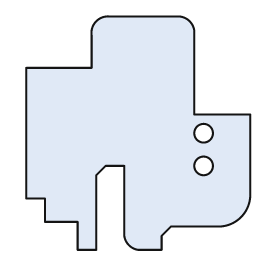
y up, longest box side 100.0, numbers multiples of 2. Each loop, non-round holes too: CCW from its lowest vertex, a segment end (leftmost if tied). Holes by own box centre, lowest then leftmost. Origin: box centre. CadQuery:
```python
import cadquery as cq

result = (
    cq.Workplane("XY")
    .moveTo(-26.0, -50.0)
    .lineTo(-18.0, -50.0)
    .lineTo(-18.0, -18.0)
    .lineTo(-14.0, -14.0)
    .lineTo(-6.0, -14.0)
    .lineTo(-6.0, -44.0)
    .threePointArc((-4.0, -48.0), (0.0, -50.0))
    .lineTo(10.0, -50.0)
    .lineTo(10.0, -44.0)
    .lineTo(14.0, -40.0)
    .lineTo(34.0, -40.0)
    .threePointArc((44.0, -36.0), (48.0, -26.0))
    .lineTo(48.0, 8.0)
    .lineTo(24.0, 8.0)
    .lineTo(24.0, 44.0)
    .threePointArc((22.0, 48.0), (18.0, 50.0))
    .lineTo(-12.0, 50.0)
    .threePointArc((-18.0, 48.0), (-20.0, 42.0))
    .lineTo(-20.0, 28.0)
    .lineTo(-48.0, 28.0)
    .lineTo(-48.0, -28.0)
    .lineTo(-40.0, -28.0)
    .lineTo(-40.0, -38.0)
    .lineTo(-26.0, -38.0)
    .close()
    .moveTo(28.0, -14.0)
    .circle(4.0)
    .moveTo(28.0, 0.0)
    .circle(4.0)
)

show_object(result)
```